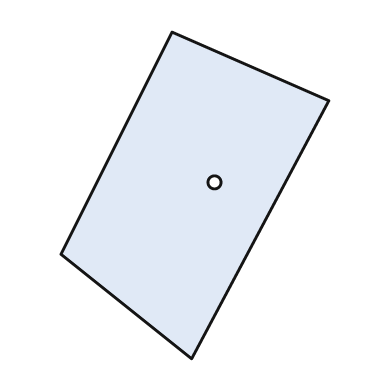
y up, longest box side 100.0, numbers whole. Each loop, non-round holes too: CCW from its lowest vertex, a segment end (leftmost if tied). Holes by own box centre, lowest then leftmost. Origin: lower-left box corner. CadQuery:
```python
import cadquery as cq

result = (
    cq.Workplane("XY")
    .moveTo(40.0, 0.0)
    .lineTo(82.0, 79.0)
    .lineTo(34.0, 100.0)
    .lineTo(0.0, 32.0)
    .close()
    .moveTo(47.0, 54.0)
    .circle(2.0)
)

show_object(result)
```